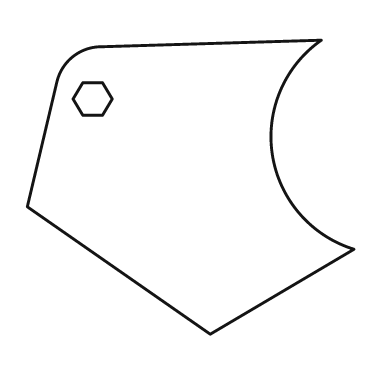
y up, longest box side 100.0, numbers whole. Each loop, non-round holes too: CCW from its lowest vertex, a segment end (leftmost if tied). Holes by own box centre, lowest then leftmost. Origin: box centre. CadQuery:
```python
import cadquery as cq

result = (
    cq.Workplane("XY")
    .moveTo(6.0, -45.0)
    .lineTo(50.0, -19.0)
    .threePointArc((25.0, 10.0), (40.0, 45.0))
    .lineTo(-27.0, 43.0)
    .threePointArc((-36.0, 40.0), (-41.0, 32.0))
    .lineTo(-50.0, -6.0)
    .close()
    .moveTo(-33.0, 22.0)
    .lineTo(-27.0, 22.0)
    .lineTo(-24.0, 27.0)
    .lineTo(-27.0, 32.0)
    .lineTo(-33.0, 32.0)
    .lineTo(-36.0, 27.0)
    .close()
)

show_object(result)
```